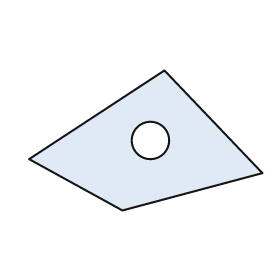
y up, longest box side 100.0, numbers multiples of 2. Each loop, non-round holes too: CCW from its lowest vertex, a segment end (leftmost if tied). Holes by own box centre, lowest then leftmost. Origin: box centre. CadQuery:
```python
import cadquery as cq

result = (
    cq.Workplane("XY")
    .moveTo(-10.0, -30.0)
    .lineTo(50.0, -14.0)
    .lineTo(8.0, 30.0)
    .lineTo(-50.0, -8.0)
    .close()
    .moveTo(2.0, 0.0)
    .circle(8.0)
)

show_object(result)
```